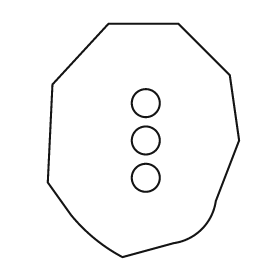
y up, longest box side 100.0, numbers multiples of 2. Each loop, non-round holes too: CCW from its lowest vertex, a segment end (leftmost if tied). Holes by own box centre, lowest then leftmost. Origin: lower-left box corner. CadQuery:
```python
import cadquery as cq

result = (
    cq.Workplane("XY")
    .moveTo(32.0, 0.0)
    .lineTo(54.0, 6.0)
    .threePointArc((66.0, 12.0), (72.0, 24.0))
    .lineTo(82.0, 50.0)
    .lineTo(78.0, 78.0)
    .lineTo(56.0, 100.0)
    .lineTo(26.0, 100.0)
    .lineTo(2.0, 74.0)
    .lineTo(0.0, 32.0)
    .lineTo(10.0, 18.0)
    .threePointArc((20.0, 8.0), (32.0, 0.0))
    .close()
    .moveTo(42.0, 34.0)
    .circle(6.0)
    .moveTo(42.0, 50.0)
    .circle(6.0)
    .moveTo(42.0, 66.0)
    .circle(6.0)
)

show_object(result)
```